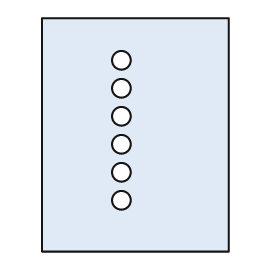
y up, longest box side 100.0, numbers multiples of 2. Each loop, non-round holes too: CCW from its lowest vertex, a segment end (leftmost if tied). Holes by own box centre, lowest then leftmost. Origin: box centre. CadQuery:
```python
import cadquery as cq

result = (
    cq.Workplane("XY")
    .moveTo(-40.0, -50.0)
    .lineTo(40.0, -50.0)
    .lineTo(40.0, 50.0)
    .lineTo(-40.0, 50.0)
    .close()
    .moveTo(-6.0, -28.0)
    .circle(4.0)
    .moveTo(-6.0, -16.0)
    .circle(4.0)
    .moveTo(-6.0, -4.0)
    .circle(4.0)
    .moveTo(-6.0, 8.0)
    .circle(4.0)
    .moveTo(-6.0, 20.0)
    .circle(4.0)
    .moveTo(-6.0, 32.0)
    .circle(4.0)
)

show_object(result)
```